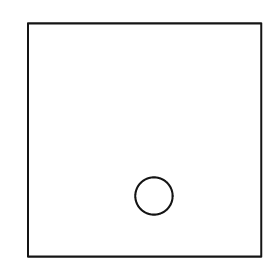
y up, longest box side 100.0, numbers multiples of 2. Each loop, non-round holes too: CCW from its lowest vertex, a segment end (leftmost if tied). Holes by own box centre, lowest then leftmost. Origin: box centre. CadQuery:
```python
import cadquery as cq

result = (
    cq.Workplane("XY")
    .moveTo(-50.0, -50.0)
    .lineTo(50.0, -50.0)
    .lineTo(50.0, 50.0)
    .lineTo(-50.0, 50.0)
    .close()
    .moveTo(4.0, -24.0)
    .circle(8.0)
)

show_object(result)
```